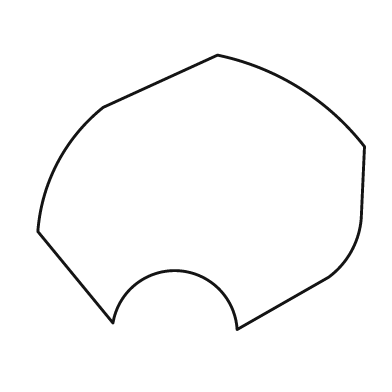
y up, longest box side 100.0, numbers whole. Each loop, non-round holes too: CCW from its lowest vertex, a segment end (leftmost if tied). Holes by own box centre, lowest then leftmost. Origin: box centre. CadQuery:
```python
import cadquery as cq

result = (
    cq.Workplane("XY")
    .moveTo(11.0, -42.0)
    .lineTo(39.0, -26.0)
    .threePointArc((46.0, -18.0), (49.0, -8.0))
    .lineTo(50.0, 14.0)
    .threePointArc((30.0, 32.0), (5.0, 42.0))
    .lineTo(-30.0, 26.0)
    .threePointArc((-44.0, 9.0), (-50.0, -12.0))
    .lineTo(-27.0, -40.0)
    .threePointArc((-7.0, -24.0), (11.0, -42.0))
    .close()
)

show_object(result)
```